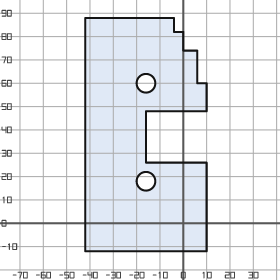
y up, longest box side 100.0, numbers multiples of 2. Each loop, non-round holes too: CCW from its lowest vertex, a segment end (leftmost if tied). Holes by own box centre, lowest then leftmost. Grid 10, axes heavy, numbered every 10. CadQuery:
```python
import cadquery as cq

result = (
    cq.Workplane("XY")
    .moveTo(-42.0, -12.0)
    .lineTo(10.0, -12.0)
    .lineTo(10.0, 26.0)
    .lineTo(-16.0, 26.0)
    .lineTo(-16.0, 48.0)
    .lineTo(10.0, 48.0)
    .lineTo(10.0, 60.0)
    .lineTo(6.0, 60.0)
    .lineTo(6.0, 74.0)
    .lineTo(0.0, 74.0)
    .lineTo(0.0, 82.0)
    .lineTo(-4.0, 82.0)
    .lineTo(-4.0, 88.0)
    .lineTo(-42.0, 88.0)
    .close()
    .moveTo(-16.0, 18.0)
    .circle(4.0)
    .moveTo(-16.0, 60.0)
    .circle(4.0)
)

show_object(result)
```